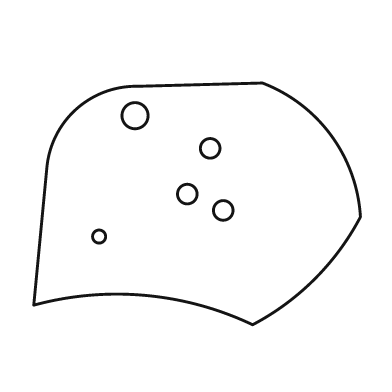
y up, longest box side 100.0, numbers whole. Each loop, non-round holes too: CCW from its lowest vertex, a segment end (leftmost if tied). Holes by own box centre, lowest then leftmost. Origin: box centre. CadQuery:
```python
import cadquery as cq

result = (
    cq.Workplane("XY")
    .moveTo(17.0, -37.0)
    .threePointArc((36.0, -23.0), (50.0, -4.0))
    .threePointArc((41.0, 21.0), (20.0, 37.0))
    .lineTo(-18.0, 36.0)
    .threePointArc((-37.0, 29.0), (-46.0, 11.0))
    .lineTo(-50.0, -31.0)
    .threePointArc((-16.0, -28.0), (17.0, -37.0))
    .close()
    .moveTo(-30.0, -10.0)
    .circle(2.0)
    .moveTo(8.0, -2.0)
    .circle(3.0)
    .moveTo(-3.0, 3.0)
    .circle(3.0)
    .moveTo(4.0, 17.0)
    .circle(3.0)
    .moveTo(-19.0, 27.0)
    .circle(4.0)
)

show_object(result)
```